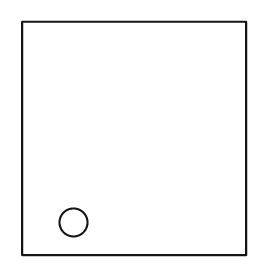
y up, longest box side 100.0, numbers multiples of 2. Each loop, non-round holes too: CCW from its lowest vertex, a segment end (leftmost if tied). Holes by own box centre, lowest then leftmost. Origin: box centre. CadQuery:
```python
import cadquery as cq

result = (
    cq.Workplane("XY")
    .moveTo(-48.0, -50.0)
    .lineTo(48.0, -50.0)
    .lineTo(48.0, 50.0)
    .lineTo(-48.0, 50.0)
    .close()
    .moveTo(-26.0, -36.0)
    .circle(6.0)
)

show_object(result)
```